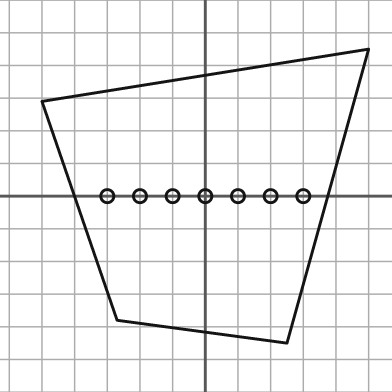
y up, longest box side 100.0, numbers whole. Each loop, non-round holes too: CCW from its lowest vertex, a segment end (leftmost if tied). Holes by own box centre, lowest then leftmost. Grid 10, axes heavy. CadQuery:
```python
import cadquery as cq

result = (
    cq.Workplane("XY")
    .moveTo(25.0, -45.0)
    .lineTo(50.0, 45.0)
    .lineTo(-50.0, 29.0)
    .lineTo(-27.0, -38.0)
    .close()
    .moveTo(-30.0, 0.0)
    .circle(2.0)
    .moveTo(-20.0, 0.0)
    .circle(2.0)
    .moveTo(-10.0, 0.0)
    .circle(2.0)
    .moveTo(0.0, 0.0)
    .circle(2.0)
    .moveTo(10.0, 0.0)
    .circle(2.0)
    .moveTo(20.0, 0.0)
    .circle(2.0)
    .moveTo(30.0, 0.0)
    .circle(2.0)
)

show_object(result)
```